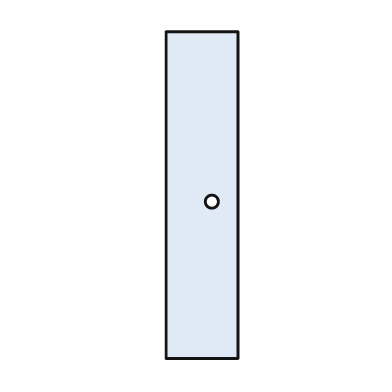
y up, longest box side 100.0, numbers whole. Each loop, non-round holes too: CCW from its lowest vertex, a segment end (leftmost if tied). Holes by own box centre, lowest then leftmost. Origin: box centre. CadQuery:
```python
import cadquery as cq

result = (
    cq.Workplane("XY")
    .moveTo(-11.0, -50.0)
    .lineTo(11.0, -50.0)
    .lineTo(11.0, 50.0)
    .lineTo(-11.0, 50.0)
    .close()
    .moveTo(3.0, -2.0)
    .circle(2.0)
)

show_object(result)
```